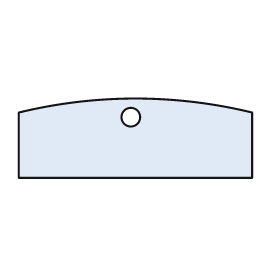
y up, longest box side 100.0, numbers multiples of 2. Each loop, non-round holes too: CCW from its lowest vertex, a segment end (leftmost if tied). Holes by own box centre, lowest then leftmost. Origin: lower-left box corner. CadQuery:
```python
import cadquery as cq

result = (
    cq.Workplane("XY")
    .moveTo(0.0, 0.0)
    .lineTo(100.0, 0.0)
    .lineTo(100.0, 28.0)
    .threePointArc((50.0, 34.0), (0.0, 28.0))
    .close()
    .moveTo(48.0, 26.0)
    .circle(4.0)
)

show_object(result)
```